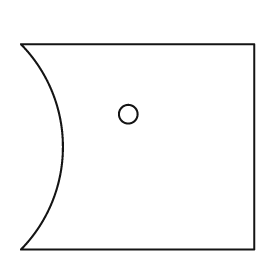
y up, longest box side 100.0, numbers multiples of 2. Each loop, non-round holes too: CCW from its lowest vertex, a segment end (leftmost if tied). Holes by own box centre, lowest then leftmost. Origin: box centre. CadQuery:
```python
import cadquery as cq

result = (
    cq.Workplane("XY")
    .moveTo(-50.0, -44.0)
    .lineTo(50.0, -44.0)
    .lineTo(50.0, 44.0)
    .lineTo(-50.0, 44.0)
    .threePointArc((-32.0, 0.0), (-50.0, -44.0))
    .close()
    .moveTo(-4.0, 14.0)
    .circle(4.0)
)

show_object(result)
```